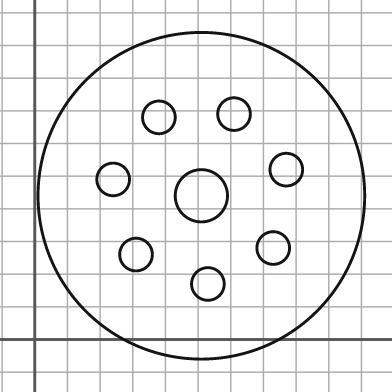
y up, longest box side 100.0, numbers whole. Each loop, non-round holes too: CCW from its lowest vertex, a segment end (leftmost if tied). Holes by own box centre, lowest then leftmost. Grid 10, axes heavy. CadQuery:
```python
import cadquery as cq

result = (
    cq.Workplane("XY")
    .moveTo(51.0, 44.0)
    .circle(50.0)
    .moveTo(53.0, 17.0)
    .circle(5.0)
    .moveTo(31.0, 26.0)
    .circle(5.0)
    .moveTo(73.0, 28.0)
    .circle(5.0)
    .moveTo(51.0, 44.0)
    .circle(8.0)
    .moveTo(24.0, 49.0)
    .circle(5.0)
    .moveTo(77.0, 52.0)
    .circle(5.0)
    .moveTo(38.0, 68.0)
    .circle(5.0)
    .moveTo(61.0, 69.0)
    .circle(5.0)
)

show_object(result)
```